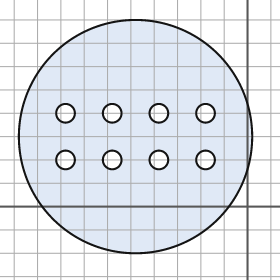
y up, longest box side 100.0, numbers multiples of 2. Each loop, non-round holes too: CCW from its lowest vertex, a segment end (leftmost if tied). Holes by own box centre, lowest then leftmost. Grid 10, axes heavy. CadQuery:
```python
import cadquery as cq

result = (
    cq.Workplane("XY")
    .moveTo(-48.0, 30.0)
    .circle(50.0)
    .moveTo(-78.0, 20.0)
    .circle(4.0)
    .moveTo(-58.0, 20.0)
    .circle(4.0)
    .moveTo(-38.0, 20.0)
    .circle(4.0)
    .moveTo(-18.0, 20.0)
    .circle(4.0)
    .moveTo(-78.0, 40.0)
    .circle(4.0)
    .moveTo(-58.0, 40.0)
    .circle(4.0)
    .moveTo(-38.0, 40.0)
    .circle(4.0)
    .moveTo(-18.0, 40.0)
    .circle(4.0)
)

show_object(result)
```